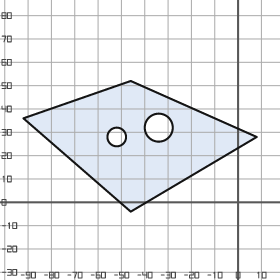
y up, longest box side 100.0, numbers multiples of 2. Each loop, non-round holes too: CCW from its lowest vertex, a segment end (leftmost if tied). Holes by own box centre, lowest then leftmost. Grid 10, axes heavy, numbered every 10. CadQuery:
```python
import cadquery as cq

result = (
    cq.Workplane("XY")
    .moveTo(-46.0, -4.0)
    .lineTo(8.0, 28.0)
    .lineTo(-46.0, 52.0)
    .lineTo(-92.0, 36.0)
    .close()
    .moveTo(-52.0, 28.0)
    .circle(4.0)
    .moveTo(-34.0, 32.0)
    .circle(6.0)
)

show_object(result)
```